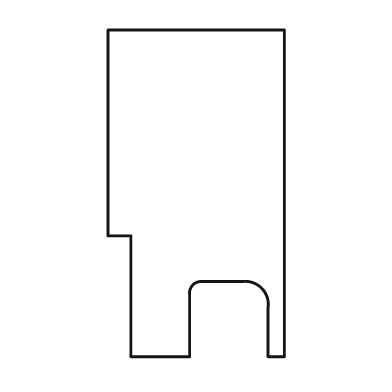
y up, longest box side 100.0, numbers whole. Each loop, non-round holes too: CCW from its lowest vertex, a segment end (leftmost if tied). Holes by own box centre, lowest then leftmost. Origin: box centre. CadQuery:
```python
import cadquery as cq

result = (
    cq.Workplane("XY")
    .moveTo(-20.0, -50.0)
    .lineTo(-2.0, -50.0)
    .lineTo(-2.0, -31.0)
    .threePointArc((-1.0, -28.0), (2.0, -27.0))
    .lineTo(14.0, -27.0)
    .threePointArc((20.0, -29.0), (22.0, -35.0))
    .lineTo(22.0, -50.0)
    .lineTo(27.0, -50.0)
    .lineTo(27.0, 50.0)
    .lineTo(-27.0, 50.0)
    .lineTo(-27.0, -13.0)
    .lineTo(-20.0, -13.0)
    .close()
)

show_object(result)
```